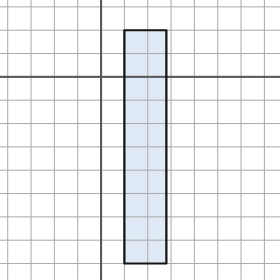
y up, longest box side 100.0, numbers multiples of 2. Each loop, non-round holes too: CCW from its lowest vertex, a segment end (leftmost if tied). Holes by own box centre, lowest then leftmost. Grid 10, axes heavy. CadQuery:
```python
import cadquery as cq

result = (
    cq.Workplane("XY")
    .moveTo(10.0, -80.0)
    .lineTo(28.0, -80.0)
    .lineTo(28.0, 20.0)
    .lineTo(10.0, 20.0)
    .close()
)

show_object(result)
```